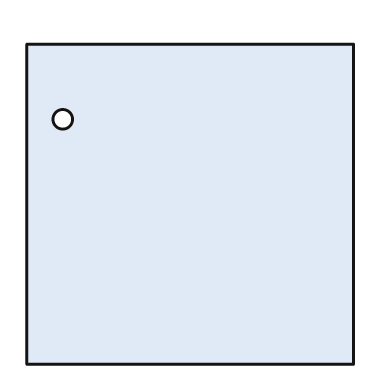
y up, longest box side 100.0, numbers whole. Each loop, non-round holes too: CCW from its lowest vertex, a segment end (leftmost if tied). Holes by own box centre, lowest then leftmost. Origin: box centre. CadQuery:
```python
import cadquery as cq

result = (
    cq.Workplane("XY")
    .moveTo(-50.0, -49.0)
    .lineTo(50.0, -49.0)
    .lineTo(50.0, 49.0)
    .lineTo(-50.0, 49.0)
    .close()
    .moveTo(-39.0, 26.0)
    .circle(3.0)
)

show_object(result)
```